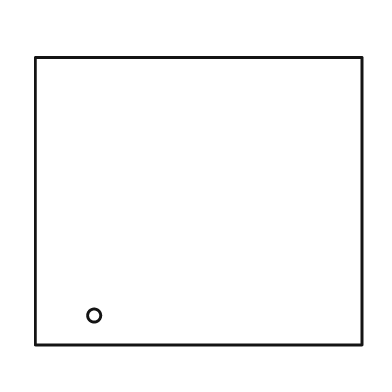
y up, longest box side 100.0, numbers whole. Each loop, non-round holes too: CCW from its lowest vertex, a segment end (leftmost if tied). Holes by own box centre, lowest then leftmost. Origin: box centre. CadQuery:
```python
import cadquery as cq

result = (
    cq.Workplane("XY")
    .moveTo(-50.0, -44.0)
    .lineTo(50.0, -44.0)
    .lineTo(50.0, 44.0)
    .lineTo(-50.0, 44.0)
    .close()
    .moveTo(-32.0, -35.0)
    .circle(2.0)
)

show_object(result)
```